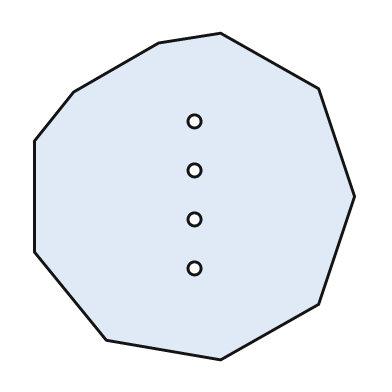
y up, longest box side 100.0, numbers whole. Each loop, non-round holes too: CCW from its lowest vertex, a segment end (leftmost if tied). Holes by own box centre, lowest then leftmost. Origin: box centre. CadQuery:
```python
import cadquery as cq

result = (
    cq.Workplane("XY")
    .moveTo(8.0, -50.0)
    .lineTo(38.0, -33.0)
    .lineTo(49.0, 0.0)
    .lineTo(38.0, 33.0)
    .lineTo(8.0, 50.0)
    .lineTo(-11.0, 47.0)
    .lineTo(-37.0, 32.0)
    .lineTo(-49.0, 17.0)
    .lineTo(-49.0, -17.0)
    .lineTo(-27.0, -44.0)
    .close()
    .moveTo(0.0, -22.0)
    .circle(2.0)
    .moveTo(0.0, -7.0)
    .circle(2.0)
    .moveTo(0.0, 8.0)
    .circle(2.0)
    .moveTo(0.0, 23.0)
    .circle(2.0)
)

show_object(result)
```